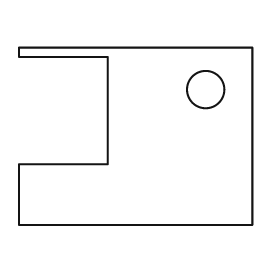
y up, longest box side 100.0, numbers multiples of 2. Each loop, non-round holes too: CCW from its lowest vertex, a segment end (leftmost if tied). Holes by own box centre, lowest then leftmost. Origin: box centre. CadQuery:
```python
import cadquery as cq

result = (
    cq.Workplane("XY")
    .moveTo(-50.0, -38.0)
    .lineTo(50.0, -38.0)
    .lineTo(50.0, 38.0)
    .lineTo(-50.0, 38.0)
    .lineTo(-50.0, 34.0)
    .lineTo(-12.0, 34.0)
    .lineTo(-12.0, -12.0)
    .lineTo(-50.0, -12.0)
    .close()
    .moveTo(30.0, 20.0)
    .circle(8.0)
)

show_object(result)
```